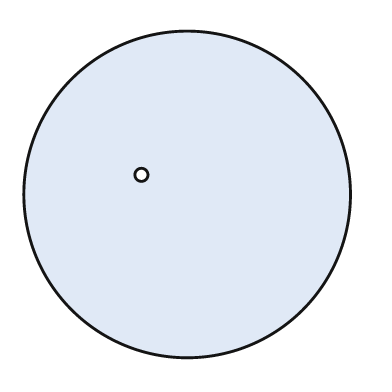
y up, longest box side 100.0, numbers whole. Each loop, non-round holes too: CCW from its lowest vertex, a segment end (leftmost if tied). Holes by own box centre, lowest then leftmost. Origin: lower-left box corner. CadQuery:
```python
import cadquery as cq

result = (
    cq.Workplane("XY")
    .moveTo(50.0, 50.0)
    .circle(50.0)
    .moveTo(36.0, 56.0)
    .circle(2.0)
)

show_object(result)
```